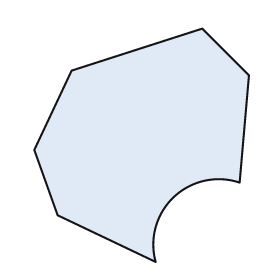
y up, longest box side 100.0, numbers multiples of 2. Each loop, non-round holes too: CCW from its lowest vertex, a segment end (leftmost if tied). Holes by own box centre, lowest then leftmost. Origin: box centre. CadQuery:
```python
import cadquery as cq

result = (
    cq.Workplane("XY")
    .moveTo(6.0, -50.0)
    .threePointArc((14.0, -22.0), (42.0, -16.0))
    .lineTo(46.0, 30.0)
    .lineTo(26.0, 50.0)
    .lineTo(-30.0, 32.0)
    .lineTo(-46.0, -2.0)
    .lineTo(-36.0, -30.0)
    .close()
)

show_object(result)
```